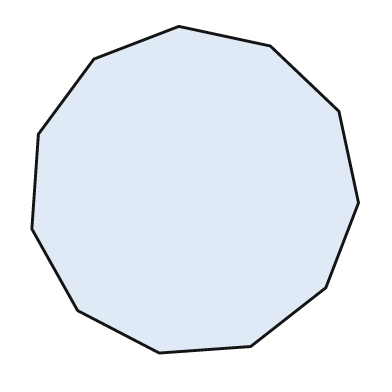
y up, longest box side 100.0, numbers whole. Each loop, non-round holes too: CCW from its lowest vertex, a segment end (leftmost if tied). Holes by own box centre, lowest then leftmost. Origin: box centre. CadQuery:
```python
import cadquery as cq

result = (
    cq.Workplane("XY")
    .moveTo(-11.0, -50.0)
    .lineTo(17.0, -48.0)
    .lineTo(40.0, -30.0)
    .lineTo(50.0, -4.0)
    .lineTo(44.0, 24.0)
    .lineTo(23.0, 44.0)
    .lineTo(-5.0, 50.0)
    .lineTo(-31.0, 40.0)
    .lineTo(-48.0, 17.0)
    .lineTo(-50.0, -12.0)
    .lineTo(-36.0, -37.0)
    .close()
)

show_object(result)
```